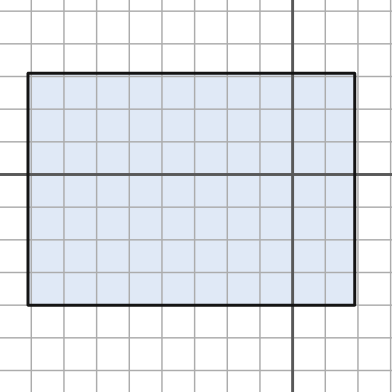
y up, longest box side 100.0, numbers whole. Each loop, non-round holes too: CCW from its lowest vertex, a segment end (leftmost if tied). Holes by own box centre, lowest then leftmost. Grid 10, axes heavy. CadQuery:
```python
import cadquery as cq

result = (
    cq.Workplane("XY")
    .moveTo(-81.0, -40.0)
    .lineTo(19.0, -40.0)
    .lineTo(19.0, 31.0)
    .lineTo(-81.0, 31.0)
    .close()
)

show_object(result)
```